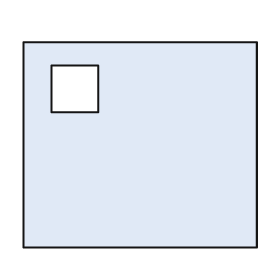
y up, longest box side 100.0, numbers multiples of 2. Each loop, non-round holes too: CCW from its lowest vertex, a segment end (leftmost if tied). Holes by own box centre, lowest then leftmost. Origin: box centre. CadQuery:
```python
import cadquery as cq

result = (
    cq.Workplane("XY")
    .moveTo(-50.0, -44.0)
    .lineTo(50.0, -44.0)
    .lineTo(50.0, 44.0)
    .lineTo(-50.0, 44.0)
    .close()
    .moveTo(-38.0, 14.0)
    .lineTo(-18.0, 14.0)
    .lineTo(-18.0, 34.0)
    .lineTo(-38.0, 34.0)
    .close()
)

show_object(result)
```